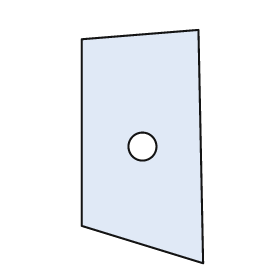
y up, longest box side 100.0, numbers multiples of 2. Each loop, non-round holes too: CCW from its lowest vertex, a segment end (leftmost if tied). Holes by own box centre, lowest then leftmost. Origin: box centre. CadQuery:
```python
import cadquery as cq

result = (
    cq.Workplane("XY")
    .moveTo(26.0, -50.0)
    .lineTo(24.0, 50.0)
    .lineTo(-26.0, 46.0)
    .lineTo(-26.0, -34.0)
    .close()
    .moveTo(0.0, 0.0)
    .circle(6.0)
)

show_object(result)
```